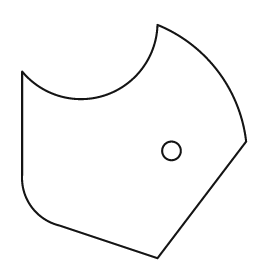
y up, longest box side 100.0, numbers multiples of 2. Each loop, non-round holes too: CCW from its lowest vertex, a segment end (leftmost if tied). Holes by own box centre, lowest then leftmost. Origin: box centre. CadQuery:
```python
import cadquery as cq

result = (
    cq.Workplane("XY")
    .moveTo(10.0, -50.0)
    .lineTo(48.0, 0.0)
    .threePointArc((36.0, 30.0), (10.0, 50.0))
    .threePointArc((-12.0, 20.0), (-48.0, 30.0))
    .lineTo(-48.0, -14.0)
    .threePointArc((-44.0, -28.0), (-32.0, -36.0))
    .close()
    .moveTo(16.0, -4.0)
    .circle(4.0)
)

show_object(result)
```